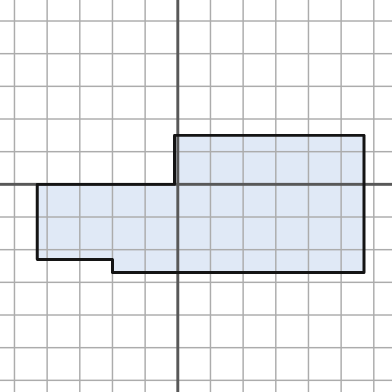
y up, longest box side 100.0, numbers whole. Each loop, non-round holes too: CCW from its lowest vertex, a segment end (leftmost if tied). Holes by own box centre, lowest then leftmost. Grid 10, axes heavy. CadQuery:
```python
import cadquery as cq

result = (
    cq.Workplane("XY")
    .moveTo(-20.0, -27.0)
    .lineTo(57.0, -27.0)
    .lineTo(57.0, 15.0)
    .lineTo(-1.0, 15.0)
    .lineTo(-1.0, 0.0)
    .lineTo(-43.0, 0.0)
    .lineTo(-43.0, -23.0)
    .lineTo(-20.0, -23.0)
    .close()
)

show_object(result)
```